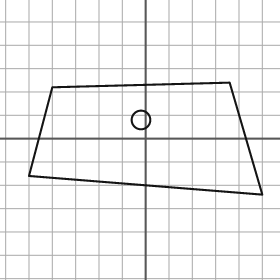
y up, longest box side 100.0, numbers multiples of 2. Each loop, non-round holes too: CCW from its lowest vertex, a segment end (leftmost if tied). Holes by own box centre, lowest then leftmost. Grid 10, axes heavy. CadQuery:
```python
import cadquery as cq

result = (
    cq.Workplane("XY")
    .moveTo(50.0, -24.0)
    .lineTo(36.0, 24.0)
    .lineTo(-40.0, 22.0)
    .lineTo(-50.0, -16.0)
    .close()
    .moveTo(-2.0, 8.0)
    .circle(4.0)
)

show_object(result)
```